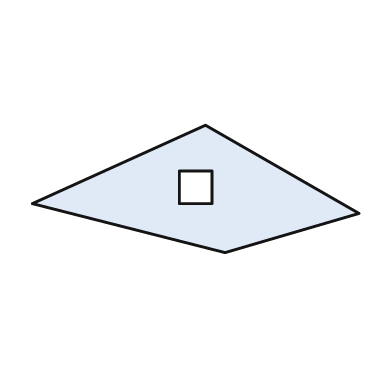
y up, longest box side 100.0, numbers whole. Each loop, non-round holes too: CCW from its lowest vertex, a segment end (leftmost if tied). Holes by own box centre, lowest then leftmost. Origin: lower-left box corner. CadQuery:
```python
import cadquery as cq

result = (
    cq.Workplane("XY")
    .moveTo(59.0, 0.0)
    .lineTo(100.0, 12.0)
    .lineTo(53.0, 39.0)
    .lineTo(0.0, 15.0)
    .close()
    .moveTo(45.0, 15.0)
    .lineTo(55.0, 15.0)
    .lineTo(55.0, 25.0)
    .lineTo(45.0, 25.0)
    .close()
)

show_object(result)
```